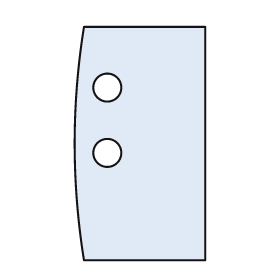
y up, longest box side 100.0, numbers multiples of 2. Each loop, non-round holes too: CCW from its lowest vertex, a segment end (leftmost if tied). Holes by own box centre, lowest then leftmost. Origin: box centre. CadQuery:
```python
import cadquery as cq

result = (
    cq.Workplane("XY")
    .moveTo(-24.0, -50.0)
    .lineTo(28.0, -50.0)
    .lineTo(28.0, 50.0)
    .lineTo(-24.0, 50.0)
    .threePointArc((-28.0, 0.0), (-24.0, -50.0))
    .close()
    .moveTo(-14.0, -4.0)
    .circle(6.0)
    .moveTo(-14.0, 24.0)
    .circle(6.0)
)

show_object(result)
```